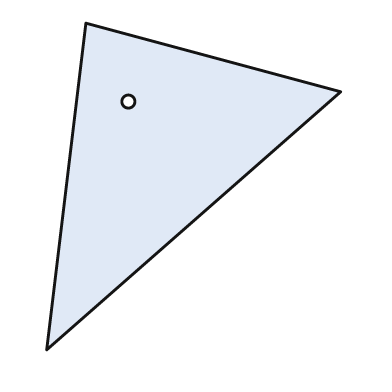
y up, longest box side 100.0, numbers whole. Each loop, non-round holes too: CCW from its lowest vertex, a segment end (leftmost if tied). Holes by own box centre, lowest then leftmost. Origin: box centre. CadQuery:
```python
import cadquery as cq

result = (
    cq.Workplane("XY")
    .moveTo(-45.0, -50.0)
    .lineTo(45.0, 29.0)
    .lineTo(-33.0, 50.0)
    .close()
    .moveTo(-20.0, 26.0)
    .circle(2.0)
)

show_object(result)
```